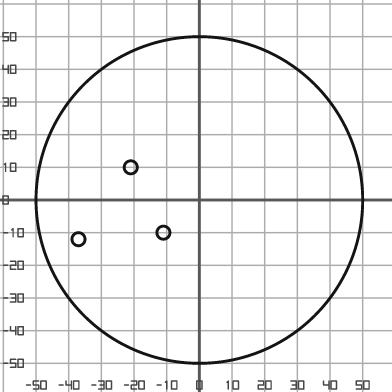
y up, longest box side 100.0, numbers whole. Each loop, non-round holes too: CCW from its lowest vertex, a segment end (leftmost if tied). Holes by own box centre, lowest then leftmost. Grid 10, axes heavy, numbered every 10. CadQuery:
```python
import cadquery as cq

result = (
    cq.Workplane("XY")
    .moveTo(0.0, 0.0)
    .circle(50.0)
    .moveTo(-37.0, -12.0)
    .circle(2.0)
    .moveTo(-11.0, -10.0)
    .circle(2.0)
    .moveTo(-21.0, 10.0)
    .circle(2.0)
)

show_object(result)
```